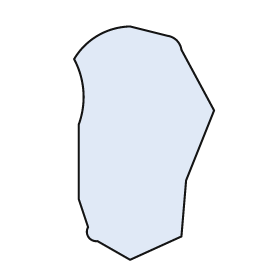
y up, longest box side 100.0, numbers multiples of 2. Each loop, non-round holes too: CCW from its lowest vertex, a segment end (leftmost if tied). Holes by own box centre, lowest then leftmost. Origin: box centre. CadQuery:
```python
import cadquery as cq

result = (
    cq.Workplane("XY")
    .moveTo(-6.0, -50.0)
    .lineTo(16.0, -40.0)
    .lineTo(18.0, -16.0)
    .lineTo(30.0, 14.0)
    .lineTo(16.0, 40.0)
    .threePointArc((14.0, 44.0), (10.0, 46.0))
    .lineTo(-6.0, 50.0)
    .threePointArc((-20.0, 46.0), (-30.0, 36.0))
    .threePointArc((-26.0, 22.0), (-28.0, 8.0))
    .lineTo(-28.0, -24.0)
    .lineTo(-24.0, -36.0)
    .threePointArc((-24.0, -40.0), (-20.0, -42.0))
    .close()
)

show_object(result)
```